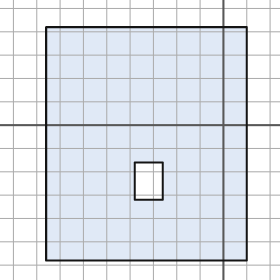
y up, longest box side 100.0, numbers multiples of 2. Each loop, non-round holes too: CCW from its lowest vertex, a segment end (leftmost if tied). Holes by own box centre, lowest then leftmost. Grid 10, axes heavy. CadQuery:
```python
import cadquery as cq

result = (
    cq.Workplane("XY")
    .moveTo(-76.0, -58.0)
    .lineTo(10.0, -58.0)
    .lineTo(10.0, 42.0)
    .lineTo(-76.0, 42.0)
    .close()
    .moveTo(-38.0, -32.0)
    .lineTo(-26.0, -32.0)
    .lineTo(-26.0, -16.0)
    .lineTo(-38.0, -16.0)
    .close()
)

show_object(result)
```